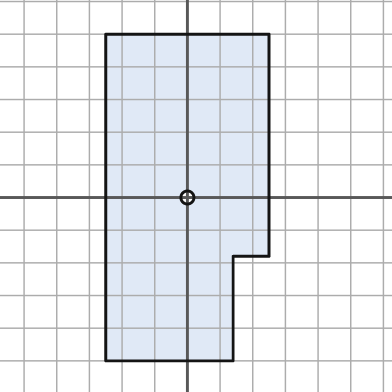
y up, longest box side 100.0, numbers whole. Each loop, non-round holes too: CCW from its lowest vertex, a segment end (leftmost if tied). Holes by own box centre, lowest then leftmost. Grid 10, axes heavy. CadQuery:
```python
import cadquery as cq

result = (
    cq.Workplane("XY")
    .moveTo(-25.0, -50.0)
    .lineTo(14.0, -50.0)
    .lineTo(14.0, -18.0)
    .lineTo(25.0, -18.0)
    .lineTo(25.0, 50.0)
    .lineTo(-25.0, 50.0)
    .close()
    .moveTo(0.0, 0.0)
    .circle(2.0)
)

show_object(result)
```